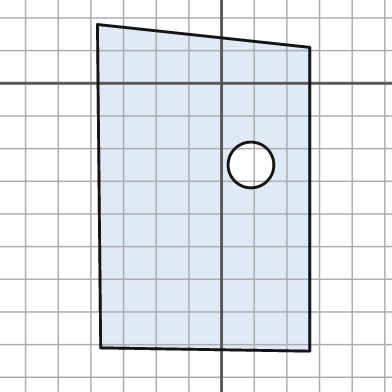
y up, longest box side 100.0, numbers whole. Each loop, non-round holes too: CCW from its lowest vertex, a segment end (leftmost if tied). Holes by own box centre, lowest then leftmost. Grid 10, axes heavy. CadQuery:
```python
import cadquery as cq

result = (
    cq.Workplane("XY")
    .moveTo(27.0, -82.0)
    .lineTo(27.0, 11.0)
    .lineTo(-38.0, 18.0)
    .lineTo(-37.0, -81.0)
    .close()
    .moveTo(9.0, -25.0)
    .circle(7.0)
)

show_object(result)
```